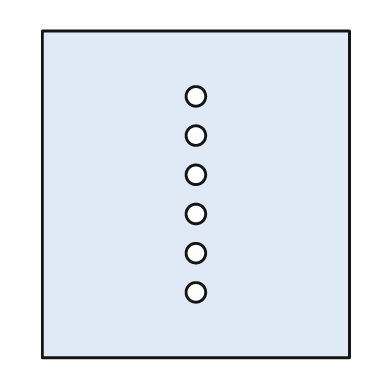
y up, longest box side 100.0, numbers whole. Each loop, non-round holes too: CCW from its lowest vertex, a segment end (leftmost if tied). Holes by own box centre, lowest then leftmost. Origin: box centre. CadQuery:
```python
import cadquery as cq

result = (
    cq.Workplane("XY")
    .moveTo(-47.0, -50.0)
    .lineTo(47.0, -50.0)
    .lineTo(47.0, 50.0)
    .lineTo(-47.0, 50.0)
    .close()
    .moveTo(0.0, -30.0)
    .circle(3.0)
    .moveTo(0.0, -18.0)
    .circle(3.0)
    .moveTo(0.0, -6.0)
    .circle(3.0)
    .moveTo(0.0, 6.0)
    .circle(3.0)
    .moveTo(0.0, 18.0)
    .circle(3.0)
    .moveTo(0.0, 30.0)
    .circle(3.0)
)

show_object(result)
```